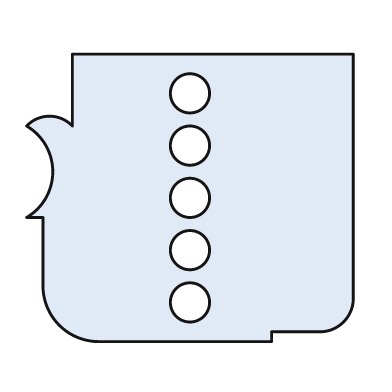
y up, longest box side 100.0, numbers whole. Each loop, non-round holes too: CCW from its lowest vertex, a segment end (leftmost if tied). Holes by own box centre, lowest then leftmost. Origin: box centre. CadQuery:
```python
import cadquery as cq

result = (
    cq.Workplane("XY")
    .moveTo(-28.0, -44.0)
    .lineTo(25.0, -44.0)
    .lineTo(25.0, -41.0)
    .lineTo(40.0, -41.0)
    .threePointArc((47.0, -38.0), (50.0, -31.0))
    .lineTo(50.0, 44.0)
    .lineTo(-36.0, 44.0)
    .lineTo(-36.0, 22.0)
    .threePointArc((-43.0, 25.0), (-50.0, 22.0))
    .threePointArc((-42.0, 8.0), (-50.0, -6.0))
    .lineTo(-45.0, -6.0)
    .lineTo(-45.0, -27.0)
    .threePointArc((-40.0, -39.0), (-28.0, -44.0))
    .close()
    .moveTo(0.0, -32.0)
    .circle(6.0)
    .moveTo(0.0, -16.0)
    .circle(6.0)
    .moveTo(0.0, 0.0)
    .circle(6.0)
    .moveTo(0.0, 16.0)
    .circle(6.0)
    .moveTo(0.0, 32.0)
    .circle(6.0)
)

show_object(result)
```